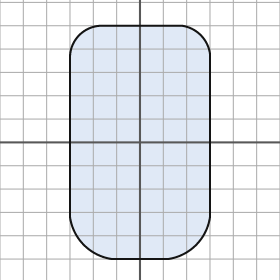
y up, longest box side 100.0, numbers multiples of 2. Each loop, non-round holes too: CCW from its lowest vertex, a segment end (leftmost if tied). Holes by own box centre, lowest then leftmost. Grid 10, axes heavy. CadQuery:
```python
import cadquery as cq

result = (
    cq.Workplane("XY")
    .moveTo(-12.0, -50.0)
    .lineTo(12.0, -50.0)
    .threePointArc((24.0, -44.0), (30.0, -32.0))
    .lineTo(30.0, 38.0)
    .threePointArc((26.0, 46.0), (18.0, 50.0))
    .lineTo(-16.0, 50.0)
    .threePointArc((-26.0, 46.0), (-30.0, 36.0))
    .lineTo(-30.0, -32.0)
    .threePointArc((-24.0, -44.0), (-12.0, -50.0))
    .close()
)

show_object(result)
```